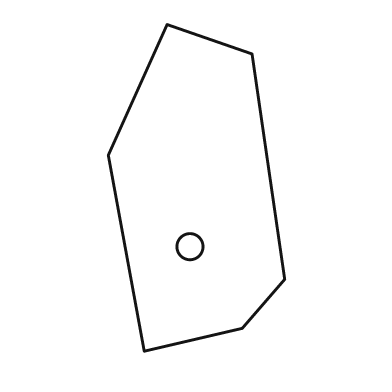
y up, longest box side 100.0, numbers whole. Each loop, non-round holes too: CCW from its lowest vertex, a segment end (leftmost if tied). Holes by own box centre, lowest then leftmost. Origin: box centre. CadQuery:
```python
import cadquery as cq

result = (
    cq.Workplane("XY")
    .moveTo(-16.0, -50.0)
    .lineTo(14.0, -43.0)
    .lineTo(27.0, -28.0)
    .lineTo(17.0, 41.0)
    .lineTo(-9.0, 50.0)
    .lineTo(-27.0, 10.0)
    .close()
    .moveTo(-2.0, -18.0)
    .circle(4.0)
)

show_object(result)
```